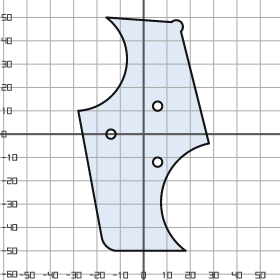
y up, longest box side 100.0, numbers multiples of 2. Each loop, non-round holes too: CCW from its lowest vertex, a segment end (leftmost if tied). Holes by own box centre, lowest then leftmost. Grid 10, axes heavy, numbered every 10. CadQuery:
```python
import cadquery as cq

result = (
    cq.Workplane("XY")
    .moveTo(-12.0, -50.0)
    .lineTo(18.0, -50.0)
    .threePointArc((8.0, -24.0), (28.0, -4.0))
    .lineTo(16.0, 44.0)
    .threePointArc((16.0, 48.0), (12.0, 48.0))
    .lineTo(-16.0, 50.0)
    .threePointArc((-8.0, 26.0), (-28.0, 10.0))
    .lineTo(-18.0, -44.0)
    .threePointArc((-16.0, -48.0), (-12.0, -50.0))
    .close()
    .moveTo(6.0, -12.0)
    .circle(2.0)
    .moveTo(-14.0, 0.0)
    .circle(2.0)
    .moveTo(6.0, 12.0)
    .circle(2.0)
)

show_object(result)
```